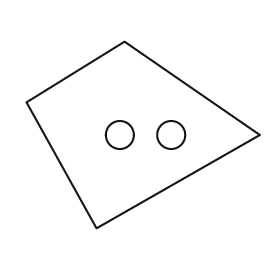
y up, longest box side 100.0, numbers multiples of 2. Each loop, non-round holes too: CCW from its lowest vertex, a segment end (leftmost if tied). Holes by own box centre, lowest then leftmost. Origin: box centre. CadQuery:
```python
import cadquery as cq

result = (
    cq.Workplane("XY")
    .moveTo(-20.0, -40.0)
    .lineTo(50.0, 0.0)
    .lineTo(-8.0, 40.0)
    .lineTo(-50.0, 14.0)
    .close()
    .moveTo(-10.0, 0.0)
    .circle(6.0)
    .moveTo(12.0, 0.0)
    .circle(6.0)
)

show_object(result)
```